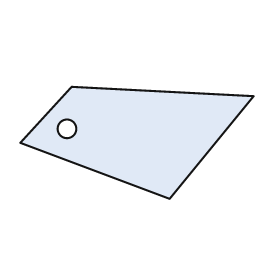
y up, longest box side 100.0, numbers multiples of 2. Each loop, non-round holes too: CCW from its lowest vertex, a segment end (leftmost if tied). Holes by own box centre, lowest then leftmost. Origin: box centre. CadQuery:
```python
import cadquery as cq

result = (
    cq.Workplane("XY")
    .moveTo(14.0, -24.0)
    .lineTo(50.0, 20.0)
    .lineTo(-28.0, 24.0)
    .lineTo(-50.0, 0.0)
    .close()
    .moveTo(-30.0, 6.0)
    .circle(4.0)
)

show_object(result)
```